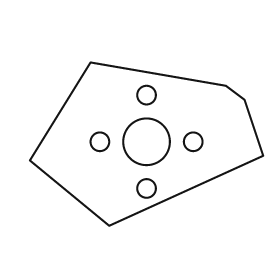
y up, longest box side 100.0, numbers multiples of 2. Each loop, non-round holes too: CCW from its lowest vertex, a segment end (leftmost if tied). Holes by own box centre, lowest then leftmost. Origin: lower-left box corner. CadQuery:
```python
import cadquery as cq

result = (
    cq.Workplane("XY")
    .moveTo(34.0, 0.0)
    .lineTo(100.0, 30.0)
    .lineTo(92.0, 54.0)
    .lineTo(84.0, 60.0)
    .lineTo(26.0, 70.0)
    .lineTo(0.0, 28.0)
    .close()
    .moveTo(50.0, 16.0)
    .circle(4.0)
    .moveTo(30.0, 36.0)
    .circle(4.0)
    .moveTo(50.0, 36.0)
    .circle(10.0)
    .moveTo(70.0, 36.0)
    .circle(4.0)
    .moveTo(50.0, 56.0)
    .circle(4.0)
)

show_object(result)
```